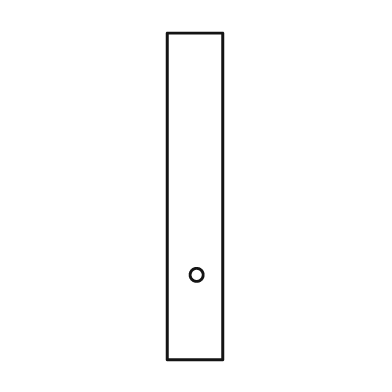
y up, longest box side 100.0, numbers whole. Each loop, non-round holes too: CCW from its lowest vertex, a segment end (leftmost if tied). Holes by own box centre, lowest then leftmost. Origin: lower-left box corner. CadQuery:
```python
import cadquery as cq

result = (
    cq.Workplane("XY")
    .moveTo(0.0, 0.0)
    .lineTo(17.0, 0.0)
    .lineTo(17.0, 100.0)
    .lineTo(0.0, 100.0)
    .close()
    .moveTo(9.0, 26.0)
    .circle(2.0)
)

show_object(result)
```